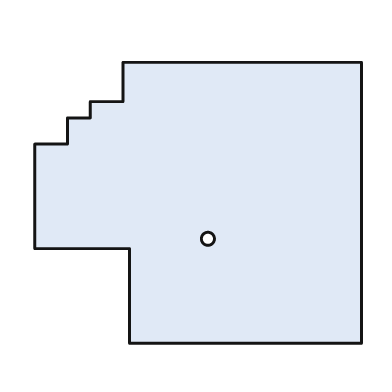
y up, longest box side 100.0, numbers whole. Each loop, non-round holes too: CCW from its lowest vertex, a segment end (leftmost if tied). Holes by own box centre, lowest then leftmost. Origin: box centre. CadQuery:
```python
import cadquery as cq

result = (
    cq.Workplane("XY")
    .moveTo(-21.0, -43.0)
    .lineTo(50.0, -43.0)
    .lineTo(50.0, 43.0)
    .lineTo(-23.0, 43.0)
    .lineTo(-23.0, 31.0)
    .lineTo(-33.0, 31.0)
    .lineTo(-33.0, 26.0)
    .lineTo(-40.0, 26.0)
    .lineTo(-40.0, 18.0)
    .lineTo(-50.0, 18.0)
    .lineTo(-50.0, -14.0)
    .lineTo(-21.0, -14.0)
    .close()
    .moveTo(3.0, -11.0)
    .circle(2.0)
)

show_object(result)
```